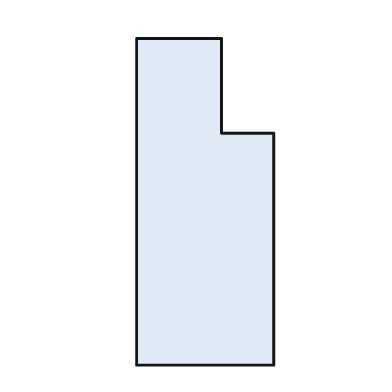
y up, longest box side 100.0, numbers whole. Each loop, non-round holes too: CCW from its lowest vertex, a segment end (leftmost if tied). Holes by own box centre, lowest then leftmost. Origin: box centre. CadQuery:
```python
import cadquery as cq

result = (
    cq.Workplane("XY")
    .moveTo(-21.0, -50.0)
    .lineTo(21.0, -50.0)
    .lineTo(21.0, 21.0)
    .lineTo(5.0, 21.0)
    .lineTo(5.0, 50.0)
    .lineTo(-21.0, 50.0)
    .close()
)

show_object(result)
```